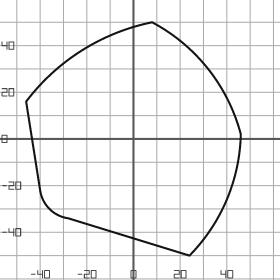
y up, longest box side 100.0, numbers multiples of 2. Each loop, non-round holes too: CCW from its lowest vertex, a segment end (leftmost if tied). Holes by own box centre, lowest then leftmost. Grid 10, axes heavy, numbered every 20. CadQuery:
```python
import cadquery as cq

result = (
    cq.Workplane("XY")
    .moveTo(24.0, -50.0)
    .threePointArc((40.0, -26.0), (46.0, 2.0))
    .threePointArc((32.0, 30.0), (8.0, 50.0))
    .threePointArc((-22.0, 38.0), (-46.0, 16.0))
    .lineTo(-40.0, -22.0)
    .threePointArc((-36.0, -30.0), (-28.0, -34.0))
    .close()
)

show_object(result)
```